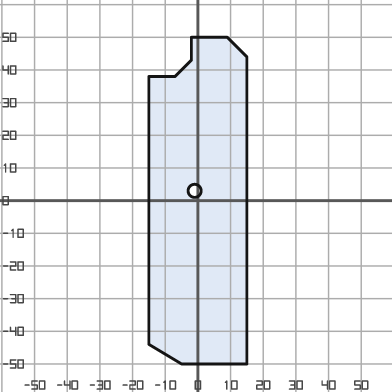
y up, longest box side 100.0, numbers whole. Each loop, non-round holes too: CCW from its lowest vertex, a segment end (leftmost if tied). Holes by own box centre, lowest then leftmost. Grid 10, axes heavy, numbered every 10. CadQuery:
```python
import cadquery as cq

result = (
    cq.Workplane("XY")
    .moveTo(-5.0, -50.0)
    .lineTo(15.0, -50.0)
    .lineTo(15.0, 44.0)
    .lineTo(9.0, 50.0)
    .lineTo(-2.0, 50.0)
    .lineTo(-2.0, 43.0)
    .lineTo(-7.0, 38.0)
    .lineTo(-15.0, 38.0)
    .lineTo(-15.0, -44.0)
    .close()
    .moveTo(-1.0, 3.0)
    .circle(2.0)
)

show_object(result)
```